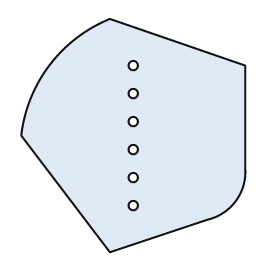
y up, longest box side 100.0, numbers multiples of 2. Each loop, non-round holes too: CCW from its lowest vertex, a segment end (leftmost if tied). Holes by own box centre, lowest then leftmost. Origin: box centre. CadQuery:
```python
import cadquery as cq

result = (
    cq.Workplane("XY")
    .moveTo(-10.0, -50.0)
    .lineTo(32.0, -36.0)
    .threePointArc((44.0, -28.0), (48.0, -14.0))
    .lineTo(48.0, 30.0)
    .lineTo(-10.0, 50.0)
    .threePointArc((-36.0, 30.0), (-48.0, 0.0))
    .close()
    .moveTo(0.0, -30.0)
    .circle(2.0)
    .moveTo(0.0, -18.0)
    .circle(2.0)
    .moveTo(0.0, -6.0)
    .circle(2.0)
    .moveTo(0.0, 6.0)
    .circle(2.0)
    .moveTo(0.0, 18.0)
    .circle(2.0)
    .moveTo(0.0, 30.0)
    .circle(2.0)
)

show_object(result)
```